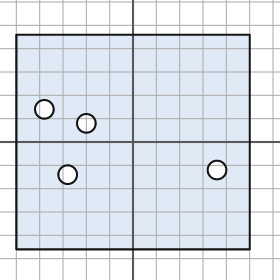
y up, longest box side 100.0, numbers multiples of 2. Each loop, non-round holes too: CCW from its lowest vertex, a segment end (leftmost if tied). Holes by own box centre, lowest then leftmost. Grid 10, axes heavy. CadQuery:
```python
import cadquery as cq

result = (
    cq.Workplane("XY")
    .moveTo(-50.0, -46.0)
    .lineTo(50.0, -46.0)
    .lineTo(50.0, 46.0)
    .lineTo(-50.0, 46.0)
    .close()
    .moveTo(-28.0, -14.0)
    .circle(4.0)
    .moveTo(36.0, -12.0)
    .circle(4.0)
    .moveTo(-20.0, 8.0)
    .circle(4.0)
    .moveTo(-38.0, 14.0)
    .circle(4.0)
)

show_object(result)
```